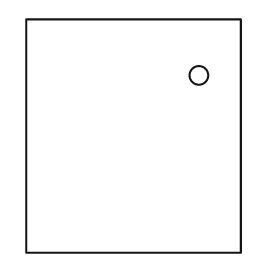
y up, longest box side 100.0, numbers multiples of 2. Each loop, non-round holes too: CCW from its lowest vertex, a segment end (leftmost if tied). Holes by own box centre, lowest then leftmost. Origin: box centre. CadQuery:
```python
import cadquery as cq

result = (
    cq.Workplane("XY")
    .moveTo(-46.0, -50.0)
    .lineTo(46.0, -50.0)
    .lineTo(46.0, 50.0)
    .lineTo(-46.0, 50.0)
    .close()
    .moveTo(28.0, 26.0)
    .circle(4.0)
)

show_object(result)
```